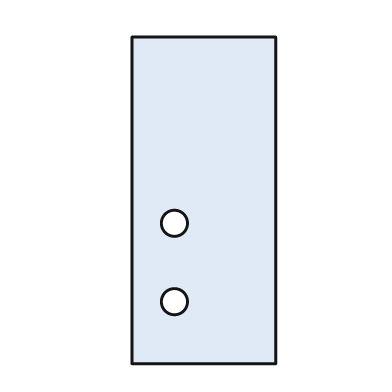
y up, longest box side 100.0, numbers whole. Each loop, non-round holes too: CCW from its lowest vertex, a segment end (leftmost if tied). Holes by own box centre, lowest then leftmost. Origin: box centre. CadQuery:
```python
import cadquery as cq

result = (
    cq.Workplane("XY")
    .moveTo(-22.0, -50.0)
    .lineTo(22.0, -50.0)
    .lineTo(22.0, 50.0)
    .lineTo(-22.0, 50.0)
    .close()
    .moveTo(-9.0, -31.0)
    .circle(4.0)
    .moveTo(-9.0, -7.0)
    .circle(4.0)
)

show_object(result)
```